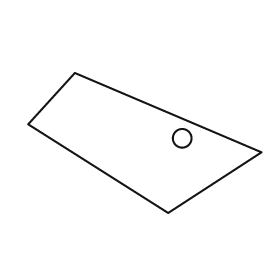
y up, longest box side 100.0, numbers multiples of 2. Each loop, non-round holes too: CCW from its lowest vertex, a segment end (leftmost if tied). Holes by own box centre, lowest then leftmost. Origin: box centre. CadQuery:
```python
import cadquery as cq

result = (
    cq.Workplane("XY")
    .moveTo(10.0, -30.0)
    .lineTo(50.0, -4.0)
    .lineTo(-30.0, 30.0)
    .lineTo(-50.0, 8.0)
    .close()
    .moveTo(16.0, 2.0)
    .circle(4.0)
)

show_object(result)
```